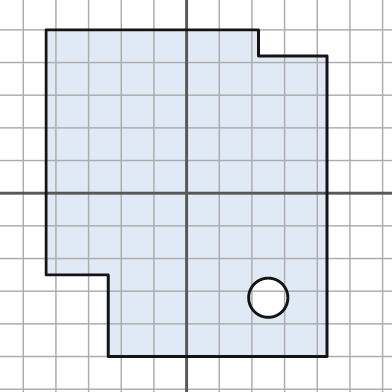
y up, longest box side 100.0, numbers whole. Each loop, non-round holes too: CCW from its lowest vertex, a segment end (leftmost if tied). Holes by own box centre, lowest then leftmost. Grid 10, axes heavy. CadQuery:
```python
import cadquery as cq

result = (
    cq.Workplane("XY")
    .moveTo(-24.0, -50.0)
    .lineTo(43.0, -50.0)
    .lineTo(43.0, 42.0)
    .lineTo(22.0, 42.0)
    .lineTo(22.0, 50.0)
    .lineTo(-43.0, 50.0)
    .lineTo(-43.0, -25.0)
    .lineTo(-24.0, -25.0)
    .close()
    .moveTo(25.0, -32.0)
    .circle(6.0)
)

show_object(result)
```